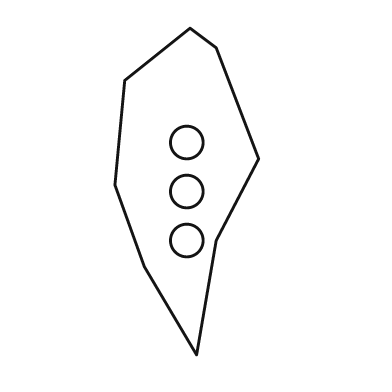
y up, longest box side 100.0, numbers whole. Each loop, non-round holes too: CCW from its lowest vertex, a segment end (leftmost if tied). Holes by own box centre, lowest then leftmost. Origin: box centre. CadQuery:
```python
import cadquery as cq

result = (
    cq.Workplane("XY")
    .moveTo(3.0, -50.0)
    .lineTo(9.0, -15.0)
    .lineTo(22.0, 10.0)
    .lineTo(9.0, 44.0)
    .lineTo(1.0, 50.0)
    .lineTo(-19.0, 34.0)
    .lineTo(-22.0, 2.0)
    .lineTo(-13.0, -23.0)
    .close()
    .moveTo(0.0, -15.0)
    .circle(5.0)
    .moveTo(0.0, 0.0)
    .circle(5.0)
    .moveTo(0.0, 15.0)
    .circle(5.0)
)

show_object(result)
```